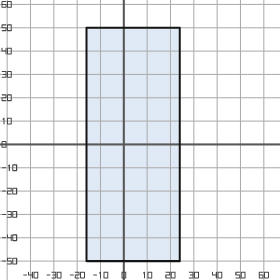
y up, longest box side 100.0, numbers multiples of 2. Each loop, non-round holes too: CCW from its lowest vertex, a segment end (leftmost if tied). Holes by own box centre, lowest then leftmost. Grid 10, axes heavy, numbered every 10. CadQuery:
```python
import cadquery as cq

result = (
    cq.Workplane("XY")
    .moveTo(-16.0, -50.0)
    .lineTo(24.0, -50.0)
    .lineTo(24.0, 50.0)
    .lineTo(-16.0, 50.0)
    .close()
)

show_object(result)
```